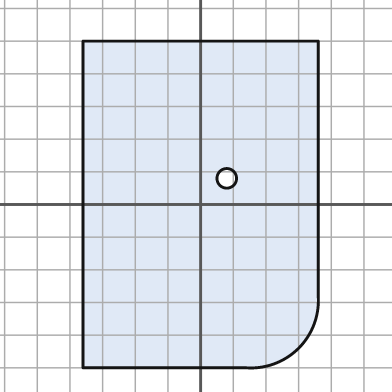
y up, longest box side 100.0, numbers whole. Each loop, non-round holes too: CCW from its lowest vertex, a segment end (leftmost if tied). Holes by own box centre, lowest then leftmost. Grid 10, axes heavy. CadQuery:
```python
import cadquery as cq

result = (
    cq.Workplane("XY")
    .moveTo(-36.0, -50.0)
    .lineTo(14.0, -50.0)
    .threePointArc((30.0, -44.0), (36.0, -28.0))
    .lineTo(36.0, 50.0)
    .lineTo(-36.0, 50.0)
    .close()
    .moveTo(8.0, 8.0)
    .circle(3.0)
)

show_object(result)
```